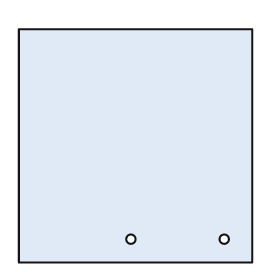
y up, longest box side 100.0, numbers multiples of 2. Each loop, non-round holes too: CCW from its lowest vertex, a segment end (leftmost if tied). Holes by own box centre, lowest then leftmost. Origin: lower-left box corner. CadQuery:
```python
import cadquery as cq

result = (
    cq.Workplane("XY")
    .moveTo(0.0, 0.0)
    .lineTo(100.0, 0.0)
    .lineTo(100.0, 100.0)
    .lineTo(0.0, 100.0)
    .close()
    .moveTo(48.0, 10.0)
    .circle(2.0)
    .moveTo(88.0, 10.0)
    .circle(2.0)
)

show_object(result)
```